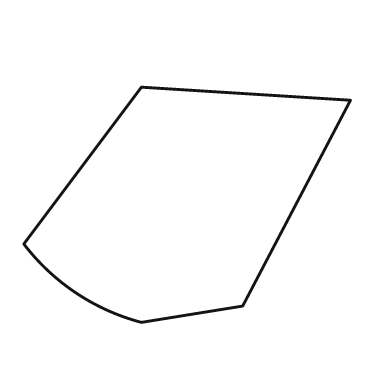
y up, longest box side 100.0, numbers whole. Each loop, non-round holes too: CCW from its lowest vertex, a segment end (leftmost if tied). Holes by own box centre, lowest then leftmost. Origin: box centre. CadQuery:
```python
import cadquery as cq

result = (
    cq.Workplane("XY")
    .moveTo(-14.0, -36.0)
    .lineTo(17.0, -31.0)
    .lineTo(50.0, 32.0)
    .lineTo(-14.0, 36.0)
    .lineTo(-50.0, -12.0)
    .threePointArc((-34.0, -27.0), (-14.0, -36.0))
    .close()
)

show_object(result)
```